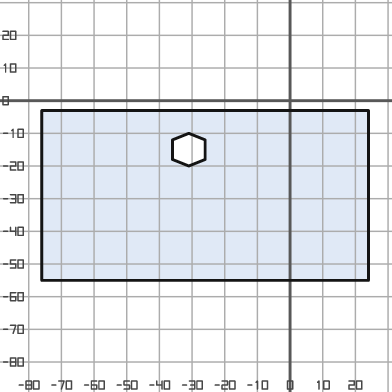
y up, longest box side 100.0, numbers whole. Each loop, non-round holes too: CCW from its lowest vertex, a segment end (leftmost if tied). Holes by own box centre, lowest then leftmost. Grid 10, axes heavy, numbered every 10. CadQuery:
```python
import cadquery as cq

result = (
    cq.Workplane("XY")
    .moveTo(-76.0, -55.0)
    .lineTo(24.0, -55.0)
    .lineTo(24.0, -3.0)
    .lineTo(-76.0, -3.0)
    .close()
    .moveTo(-31.0, -20.0)
    .lineTo(-26.0, -18.0)
    .lineTo(-26.0, -12.0)
    .lineTo(-31.0, -10.0)
    .lineTo(-36.0, -12.0)
    .lineTo(-36.0, -18.0)
    .close()
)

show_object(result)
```